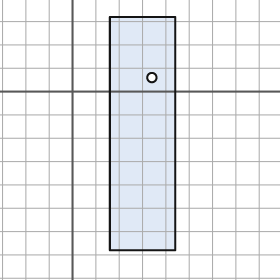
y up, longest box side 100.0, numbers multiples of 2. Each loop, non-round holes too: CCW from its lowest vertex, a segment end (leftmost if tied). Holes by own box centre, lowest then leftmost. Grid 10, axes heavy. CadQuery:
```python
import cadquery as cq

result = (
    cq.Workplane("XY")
    .moveTo(16.0, -68.0)
    .lineTo(44.0, -68.0)
    .lineTo(44.0, 32.0)
    .lineTo(16.0, 32.0)
    .close()
    .moveTo(34.0, 6.0)
    .circle(2.0)
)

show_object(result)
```